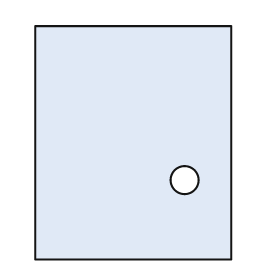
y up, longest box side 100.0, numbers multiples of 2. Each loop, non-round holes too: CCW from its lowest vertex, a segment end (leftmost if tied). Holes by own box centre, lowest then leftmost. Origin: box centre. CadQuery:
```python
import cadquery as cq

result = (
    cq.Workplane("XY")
    .moveTo(-42.0, -50.0)
    .lineTo(42.0, -50.0)
    .lineTo(42.0, 50.0)
    .lineTo(-42.0, 50.0)
    .close()
    .moveTo(22.0, -16.0)
    .circle(6.0)
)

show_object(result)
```